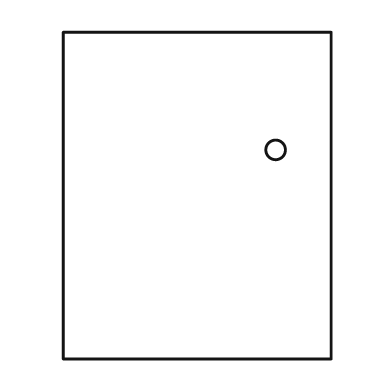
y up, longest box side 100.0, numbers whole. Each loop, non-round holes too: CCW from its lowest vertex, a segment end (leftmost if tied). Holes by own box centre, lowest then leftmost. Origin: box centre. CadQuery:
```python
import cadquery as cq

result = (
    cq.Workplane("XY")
    .moveTo(-41.0, -50.0)
    .lineTo(41.0, -50.0)
    .lineTo(41.0, 50.0)
    .lineTo(-41.0, 50.0)
    .close()
    .moveTo(24.0, 14.0)
    .circle(3.0)
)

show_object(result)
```